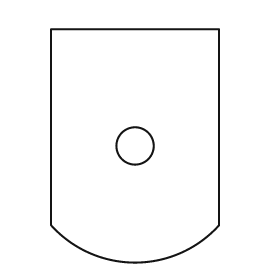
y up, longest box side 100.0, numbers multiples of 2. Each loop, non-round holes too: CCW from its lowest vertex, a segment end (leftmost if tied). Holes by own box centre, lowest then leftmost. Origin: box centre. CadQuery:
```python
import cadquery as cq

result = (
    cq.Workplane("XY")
    .moveTo(-36.0, -34.0)
    .threePointArc((0.0, -50.0), (36.0, -34.0))
    .lineTo(36.0, 50.0)
    .lineTo(-36.0, 50.0)
    .close()
    .moveTo(0.0, 0.0)
    .circle(8.0)
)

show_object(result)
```